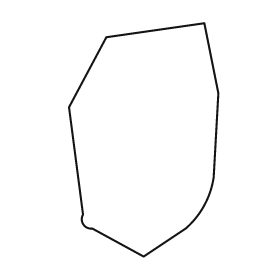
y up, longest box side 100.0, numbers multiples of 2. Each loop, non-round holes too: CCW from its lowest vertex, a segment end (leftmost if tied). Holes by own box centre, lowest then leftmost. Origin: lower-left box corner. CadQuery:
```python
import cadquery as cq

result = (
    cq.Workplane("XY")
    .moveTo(32.0, 0.0)
    .lineTo(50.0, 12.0)
    .threePointArc((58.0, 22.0), (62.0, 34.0))
    .lineTo(64.0, 70.0)
    .lineTo(58.0, 100.0)
    .lineTo(16.0, 94.0)
    .lineTo(0.0, 64.0)
    .lineTo(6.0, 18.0)
    .threePointArc((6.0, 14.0), (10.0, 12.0))
    .close()
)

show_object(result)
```